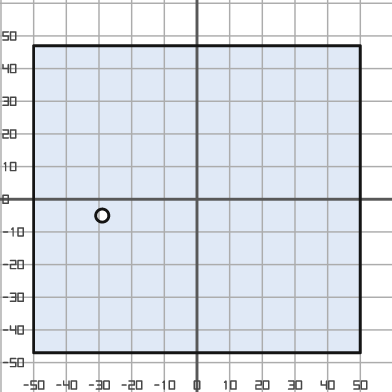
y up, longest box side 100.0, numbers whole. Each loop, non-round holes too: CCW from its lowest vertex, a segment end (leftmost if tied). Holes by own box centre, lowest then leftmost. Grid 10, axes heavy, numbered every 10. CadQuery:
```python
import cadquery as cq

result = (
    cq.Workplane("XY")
    .moveTo(-50.0, -47.0)
    .lineTo(50.0, -47.0)
    .lineTo(50.0, 47.0)
    .lineTo(-50.0, 47.0)
    .close()
    .moveTo(-29.0, -5.0)
    .circle(2.0)
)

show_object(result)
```